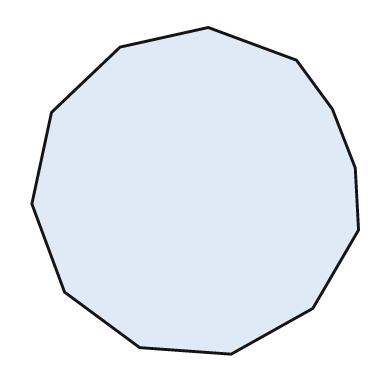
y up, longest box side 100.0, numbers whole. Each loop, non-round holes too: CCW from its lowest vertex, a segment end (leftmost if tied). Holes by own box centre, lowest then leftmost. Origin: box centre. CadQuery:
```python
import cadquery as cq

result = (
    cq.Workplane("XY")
    .moveTo(11.0, -50.0)
    .lineTo(36.0, -36.0)
    .lineTo(50.0, -12.0)
    .lineTo(49.0, 7.0)
    .lineTo(42.0, 25.0)
    .lineTo(31.0, 40.0)
    .lineTo(4.0, 50.0)
    .lineTo(-23.0, 44.0)
    .lineTo(-44.0, 24.0)
    .lineTo(-50.0, -4.0)
    .lineTo(-40.0, -31.0)
    .lineTo(-17.0, -48.0)
    .close()
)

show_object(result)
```